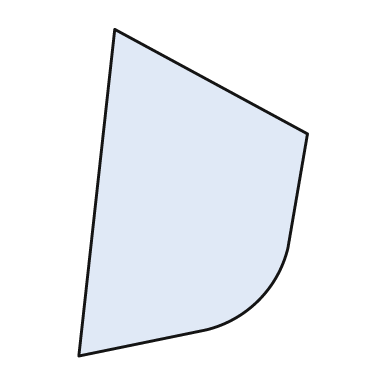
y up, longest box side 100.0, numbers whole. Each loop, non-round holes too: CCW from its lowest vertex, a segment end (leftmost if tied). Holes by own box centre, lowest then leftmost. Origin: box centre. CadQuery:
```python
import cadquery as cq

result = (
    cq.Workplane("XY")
    .moveTo(-35.0, -50.0)
    .lineTo(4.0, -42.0)
    .threePointArc((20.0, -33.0), (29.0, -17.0))
    .lineTo(35.0, 18.0)
    .lineTo(-24.0, 50.0)
    .close()
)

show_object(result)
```